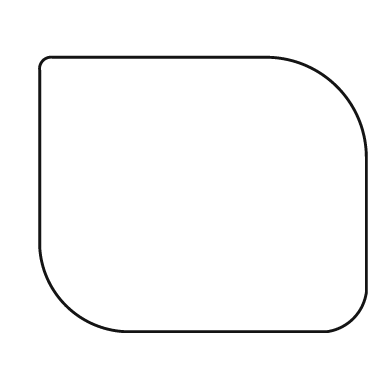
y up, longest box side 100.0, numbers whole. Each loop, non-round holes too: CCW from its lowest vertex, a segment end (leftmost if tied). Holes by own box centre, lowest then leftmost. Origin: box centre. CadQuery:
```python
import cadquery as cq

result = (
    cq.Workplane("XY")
    .moveTo(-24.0, -42.0)
    .lineTo(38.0, -42.0)
    .threePointArc((46.0, -38.0), (50.0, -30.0))
    .lineTo(50.0, 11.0)
    .threePointArc((41.0, 33.0), (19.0, 42.0))
    .lineTo(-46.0, 42.0)
    .threePointArc((-49.0, 41.0), (-50.0, 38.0))
    .lineTo(-50.0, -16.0)
    .threePointArc((-42.0, -34.0), (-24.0, -42.0))
    .close()
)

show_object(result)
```